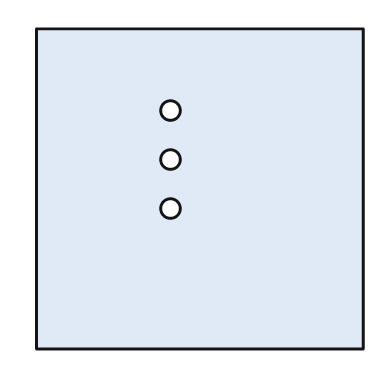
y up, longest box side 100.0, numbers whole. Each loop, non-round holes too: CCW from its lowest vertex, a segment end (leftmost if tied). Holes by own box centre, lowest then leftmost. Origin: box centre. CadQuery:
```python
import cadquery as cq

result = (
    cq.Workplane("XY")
    .moveTo(-50.0, -49.0)
    .lineTo(50.0, -49.0)
    .lineTo(50.0, 49.0)
    .lineTo(-50.0, 49.0)
    .close()
    .moveTo(-9.0, -6.0)
    .circle(3.0)
    .moveTo(-9.0, 9.0)
    .circle(3.0)
    .moveTo(-9.0, 24.0)
    .circle(3.0)
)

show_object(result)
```